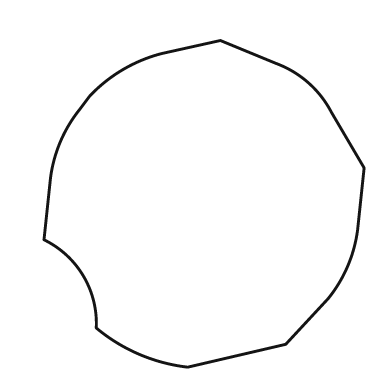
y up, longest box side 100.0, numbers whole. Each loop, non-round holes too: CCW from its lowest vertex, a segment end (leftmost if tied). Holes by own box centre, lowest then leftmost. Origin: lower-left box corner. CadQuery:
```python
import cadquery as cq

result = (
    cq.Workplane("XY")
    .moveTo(44.0, 0.0)
    .lineTo(74.0, 7.0)
    .lineTo(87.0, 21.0)
    .threePointArc((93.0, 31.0), (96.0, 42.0))
    .lineTo(98.0, 61.0)
    .lineTo(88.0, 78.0)
    .threePointArc((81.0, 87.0), (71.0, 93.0))
    .lineTo(54.0, 100.0)
    .lineTo(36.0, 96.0)
    .threePointArc((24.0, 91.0), (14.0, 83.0))
    .lineTo(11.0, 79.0)
    .threePointArc((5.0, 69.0), (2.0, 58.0))
    .lineTo(0.0, 39.0)
    .threePointArc((12.0, 28.0), (16.0, 12.0))
    .threePointArc((29.0, 4.0), (44.0, 0.0))
    .close()
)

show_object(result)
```